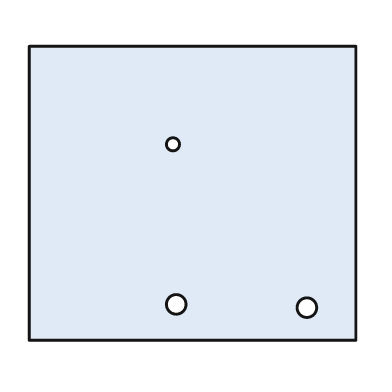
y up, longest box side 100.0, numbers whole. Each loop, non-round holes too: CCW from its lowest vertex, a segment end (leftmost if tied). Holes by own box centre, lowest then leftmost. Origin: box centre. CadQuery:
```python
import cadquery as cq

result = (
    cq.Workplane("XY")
    .moveTo(-50.0, -45.0)
    .lineTo(50.0, -45.0)
    .lineTo(50.0, 45.0)
    .lineTo(-50.0, 45.0)
    .close()
    .moveTo(35.0, -35.0)
    .circle(3.0)
    .moveTo(-5.0, -34.0)
    .circle(3.0)
    .moveTo(-6.0, 15.0)
    .circle(2.0)
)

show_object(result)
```